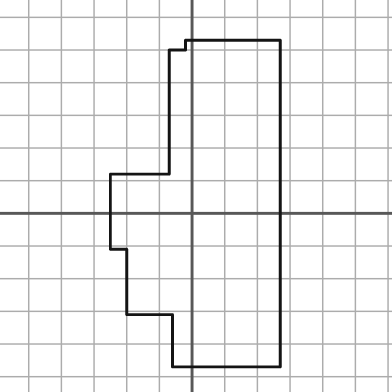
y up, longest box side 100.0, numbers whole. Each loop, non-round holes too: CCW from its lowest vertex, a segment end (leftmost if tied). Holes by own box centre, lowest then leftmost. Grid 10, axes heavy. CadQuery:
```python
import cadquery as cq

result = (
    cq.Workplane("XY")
    .moveTo(-6.0, -47.0)
    .lineTo(27.0, -47.0)
    .lineTo(27.0, 53.0)
    .lineTo(-2.0, 53.0)
    .lineTo(-2.0, 50.0)
    .lineTo(-7.0, 50.0)
    .lineTo(-7.0, 12.0)
    .lineTo(-25.0, 12.0)
    .lineTo(-25.0, -11.0)
    .lineTo(-20.0, -11.0)
    .lineTo(-20.0, -31.0)
    .lineTo(-6.0, -31.0)
    .close()
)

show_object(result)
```